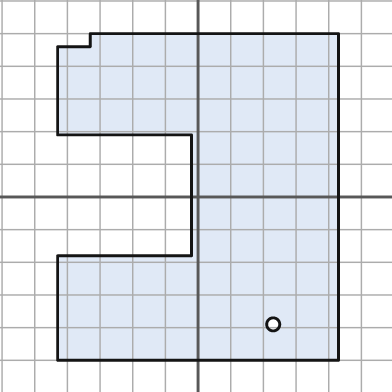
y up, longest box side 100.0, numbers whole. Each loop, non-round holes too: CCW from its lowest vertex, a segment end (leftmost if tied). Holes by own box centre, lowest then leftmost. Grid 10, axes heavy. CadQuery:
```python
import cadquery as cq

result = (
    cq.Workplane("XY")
    .moveTo(-43.0, -50.0)
    .lineTo(43.0, -50.0)
    .lineTo(43.0, 50.0)
    .lineTo(-33.0, 50.0)
    .lineTo(-33.0, 46.0)
    .lineTo(-43.0, 46.0)
    .lineTo(-43.0, 19.0)
    .lineTo(-2.0, 19.0)
    .lineTo(-2.0, -18.0)
    .lineTo(-43.0, -18.0)
    .close()
    .moveTo(23.0, -39.0)
    .circle(2.0)
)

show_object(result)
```